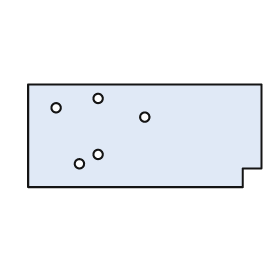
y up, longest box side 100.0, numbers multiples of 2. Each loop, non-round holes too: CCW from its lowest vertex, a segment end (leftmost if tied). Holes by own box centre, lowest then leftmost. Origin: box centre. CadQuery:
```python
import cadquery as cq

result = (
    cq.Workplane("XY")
    .moveTo(-50.0, -22.0)
    .lineTo(42.0, -22.0)
    .lineTo(42.0, -14.0)
    .lineTo(50.0, -14.0)
    .lineTo(50.0, 22.0)
    .lineTo(-50.0, 22.0)
    .close()
    .moveTo(-28.0, -12.0)
    .circle(2.0)
    .moveTo(-20.0, -8.0)
    .circle(2.0)
    .moveTo(0.0, 8.0)
    .circle(2.0)
    .moveTo(-38.0, 12.0)
    .circle(2.0)
    .moveTo(-20.0, 16.0)
    .circle(2.0)
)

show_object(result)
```